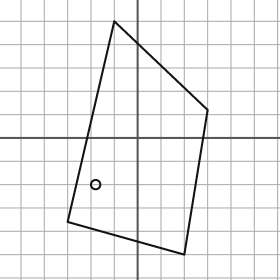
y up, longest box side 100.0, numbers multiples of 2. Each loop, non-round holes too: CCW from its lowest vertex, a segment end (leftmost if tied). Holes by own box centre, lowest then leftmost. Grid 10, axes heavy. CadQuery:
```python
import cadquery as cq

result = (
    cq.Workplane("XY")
    .moveTo(20.0, -50.0)
    .lineTo(30.0, 12.0)
    .lineTo(-10.0, 50.0)
    .lineTo(-30.0, -36.0)
    .close()
    .moveTo(-18.0, -20.0)
    .circle(2.0)
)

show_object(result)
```